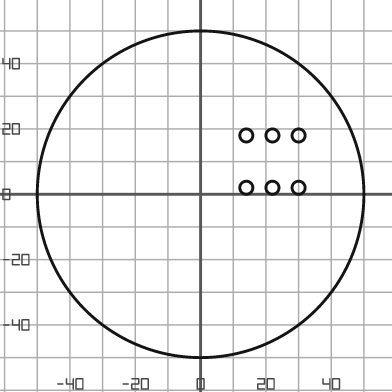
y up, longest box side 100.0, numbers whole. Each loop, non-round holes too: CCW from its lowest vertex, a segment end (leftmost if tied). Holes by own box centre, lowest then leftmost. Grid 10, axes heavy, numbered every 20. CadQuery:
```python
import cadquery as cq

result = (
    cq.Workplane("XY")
    .moveTo(0.0, 0.0)
    .circle(50.0)
    .moveTo(14.0, 2.0)
    .circle(2.0)
    .moveTo(22.0, 2.0)
    .circle(2.0)
    .moveTo(30.0, 2.0)
    .circle(2.0)
    .moveTo(14.0, 18.0)
    .circle(2.0)
    .moveTo(22.0, 18.0)
    .circle(2.0)
    .moveTo(30.0, 18.0)
    .circle(2.0)
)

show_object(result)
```